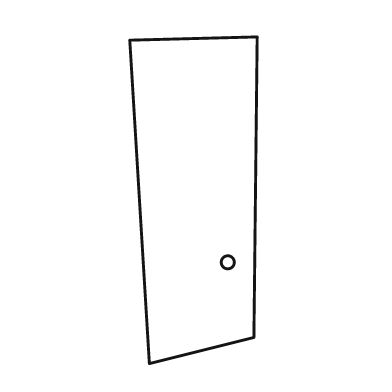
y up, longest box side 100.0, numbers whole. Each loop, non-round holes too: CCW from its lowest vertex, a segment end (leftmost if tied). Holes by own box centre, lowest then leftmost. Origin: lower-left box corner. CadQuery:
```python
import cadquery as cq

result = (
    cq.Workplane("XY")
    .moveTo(6.0, 0.0)
    .lineTo(38.0, 8.0)
    .lineTo(39.0, 100.0)
    .lineTo(0.0, 99.0)
    .close()
    .moveTo(30.0, 31.0)
    .circle(2.0)
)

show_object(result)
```